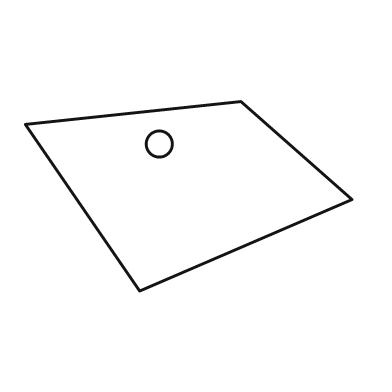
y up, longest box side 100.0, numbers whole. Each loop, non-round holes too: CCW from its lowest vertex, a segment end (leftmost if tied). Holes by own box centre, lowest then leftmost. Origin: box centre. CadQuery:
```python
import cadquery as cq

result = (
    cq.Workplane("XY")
    .moveTo(-15.0, -29.0)
    .lineTo(50.0, -1.0)
    .lineTo(16.0, 29.0)
    .lineTo(-50.0, 22.0)
    .close()
    .moveTo(-9.0, 16.0)
    .circle(4.0)
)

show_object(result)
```